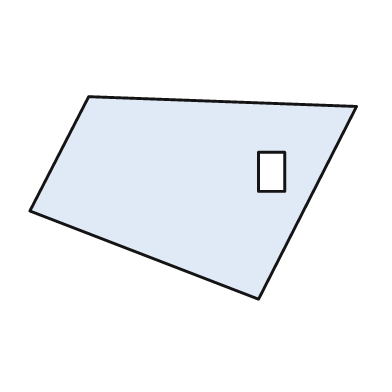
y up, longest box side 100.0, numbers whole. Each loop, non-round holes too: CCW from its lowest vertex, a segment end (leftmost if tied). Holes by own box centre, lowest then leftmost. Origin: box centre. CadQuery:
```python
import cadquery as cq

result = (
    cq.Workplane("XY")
    .moveTo(20.0, -31.0)
    .lineTo(50.0, 28.0)
    .lineTo(-32.0, 31.0)
    .lineTo(-50.0, -4.0)
    .close()
    .moveTo(20.0, 2.0)
    .lineTo(28.0, 2.0)
    .lineTo(28.0, 14.0)
    .lineTo(20.0, 14.0)
    .close()
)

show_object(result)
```